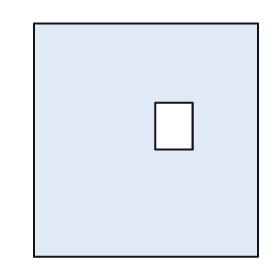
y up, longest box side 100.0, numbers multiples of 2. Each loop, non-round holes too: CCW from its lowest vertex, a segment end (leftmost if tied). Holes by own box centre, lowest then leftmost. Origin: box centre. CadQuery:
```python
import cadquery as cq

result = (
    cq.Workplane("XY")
    .moveTo(-48.0, -50.0)
    .lineTo(48.0, -50.0)
    .lineTo(48.0, 50.0)
    .lineTo(-48.0, 50.0)
    .close()
    .moveTo(4.0, -4.0)
    .lineTo(20.0, -4.0)
    .lineTo(20.0, 16.0)
    .lineTo(4.0, 16.0)
    .close()
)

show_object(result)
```